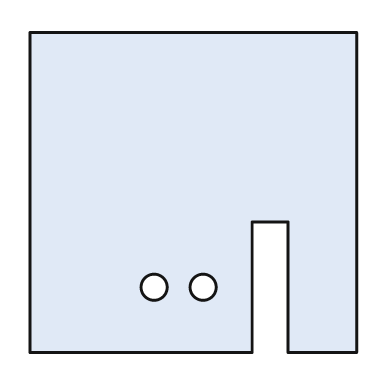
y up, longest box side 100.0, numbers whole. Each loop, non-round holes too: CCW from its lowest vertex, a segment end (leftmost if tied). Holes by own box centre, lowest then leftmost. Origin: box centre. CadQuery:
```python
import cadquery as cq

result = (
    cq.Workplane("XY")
    .moveTo(-50.0, -49.0)
    .lineTo(18.0, -49.0)
    .lineTo(18.0, -9.0)
    .lineTo(29.0, -9.0)
    .lineTo(29.0, -49.0)
    .lineTo(50.0, -49.0)
    .lineTo(50.0, 49.0)
    .lineTo(-50.0, 49.0)
    .close()
    .moveTo(-12.0, -29.0)
    .circle(4.0)
    .moveTo(3.0, -29.0)
    .circle(4.0)
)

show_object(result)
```